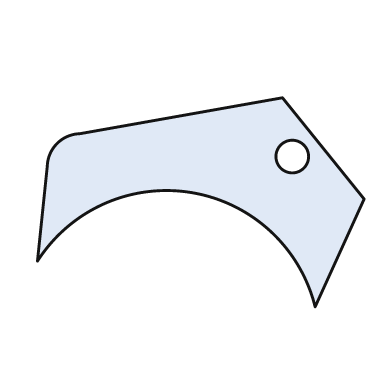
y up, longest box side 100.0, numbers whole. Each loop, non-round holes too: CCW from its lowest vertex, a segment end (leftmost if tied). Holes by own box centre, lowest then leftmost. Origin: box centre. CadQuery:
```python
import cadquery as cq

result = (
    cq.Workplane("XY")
    .moveTo(35.0, -32.0)
    .lineTo(50.0, 1.0)
    .lineTo(25.0, 32.0)
    .lineTo(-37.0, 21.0)
    .threePointArc((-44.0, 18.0), (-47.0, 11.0))
    .lineTo(-50.0, -18.0)
    .threePointArc((-3.0, 3.0), (35.0, -32.0))
    .close()
    .moveTo(28.0, 14.0)
    .circle(5.0)
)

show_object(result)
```